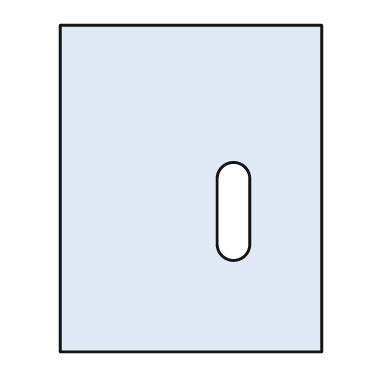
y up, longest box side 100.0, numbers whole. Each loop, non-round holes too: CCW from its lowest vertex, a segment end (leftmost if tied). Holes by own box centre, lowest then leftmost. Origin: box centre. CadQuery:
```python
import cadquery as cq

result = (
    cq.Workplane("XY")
    .moveTo(-40.0, -50.0)
    .lineTo(40.0, -50.0)
    .lineTo(40.0, 50.0)
    .lineTo(-40.0, 50.0)
    .close()
    .moveTo(8.0, -17.0)
    .threePointArc((13.0, -22.0), (18.0, -17.0))
    .lineTo(18.0, 3.0)
    .threePointArc((13.0, 8.0), (8.0, 3.0))
    .close()
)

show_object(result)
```